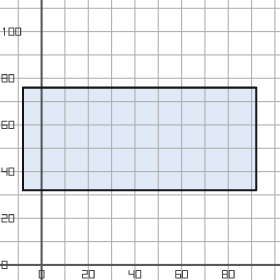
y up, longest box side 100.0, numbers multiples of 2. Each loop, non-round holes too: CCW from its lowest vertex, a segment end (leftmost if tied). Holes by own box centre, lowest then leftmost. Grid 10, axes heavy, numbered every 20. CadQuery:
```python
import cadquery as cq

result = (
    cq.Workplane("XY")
    .moveTo(-8.0, 32.0)
    .lineTo(92.0, 32.0)
    .lineTo(92.0, 76.0)
    .lineTo(-8.0, 76.0)
    .close()
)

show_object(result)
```